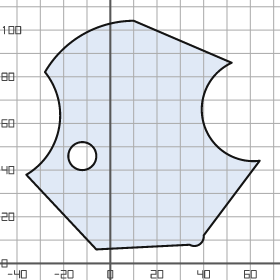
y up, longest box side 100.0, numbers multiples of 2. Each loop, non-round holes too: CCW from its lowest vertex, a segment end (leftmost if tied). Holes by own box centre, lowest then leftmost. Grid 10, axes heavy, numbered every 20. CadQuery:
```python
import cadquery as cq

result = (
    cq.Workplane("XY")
    .moveTo(-6.0, 6.0)
    .lineTo(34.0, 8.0)
    .threePointArc((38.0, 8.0), (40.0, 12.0))
    .lineTo(64.0, 44.0)
    .threePointArc((40.0, 60.0), (52.0, 86.0))
    .lineTo(10.0, 104.0)
    .threePointArc((-12.0, 98.0), (-28.0, 82.0))
    .threePointArc((-22.0, 58.0), (-36.0, 38.0))
    .close()
    .moveTo(-12.0, 46.0)
    .circle(6.0)
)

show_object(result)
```